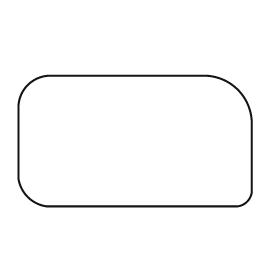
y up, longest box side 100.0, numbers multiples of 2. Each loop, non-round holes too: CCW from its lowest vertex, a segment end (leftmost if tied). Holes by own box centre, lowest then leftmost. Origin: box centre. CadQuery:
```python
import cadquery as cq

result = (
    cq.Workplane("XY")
    .moveTo(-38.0, -28.0)
    .lineTo(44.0, -28.0)
    .threePointArc((48.0, -26.0), (50.0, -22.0))
    .lineTo(50.0, 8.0)
    .threePointArc((44.0, 22.0), (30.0, 28.0))
    .lineTo(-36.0, 28.0)
    .threePointArc((-46.0, 24.0), (-50.0, 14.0))
    .lineTo(-50.0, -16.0)
    .threePointArc((-46.0, -24.0), (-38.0, -28.0))
    .close()
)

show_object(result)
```